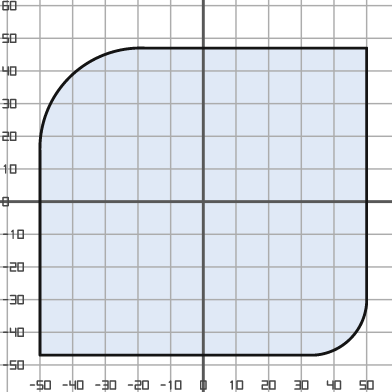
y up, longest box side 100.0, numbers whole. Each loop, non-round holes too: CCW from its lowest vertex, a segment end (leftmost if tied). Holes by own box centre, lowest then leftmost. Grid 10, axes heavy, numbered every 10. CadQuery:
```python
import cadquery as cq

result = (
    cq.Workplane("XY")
    .moveTo(-50.0, -47.0)
    .lineTo(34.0, -47.0)
    .threePointArc((45.0, -42.0), (50.0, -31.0))
    .lineTo(50.0, 47.0)
    .lineTo(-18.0, 47.0)
    .threePointArc((-41.0, 38.0), (-50.0, 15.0))
    .close()
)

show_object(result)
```